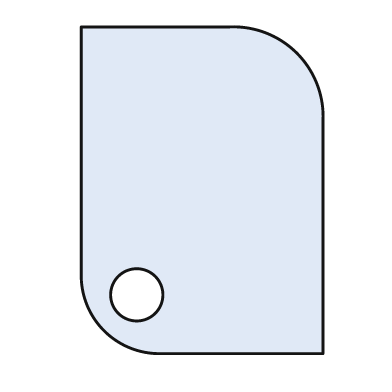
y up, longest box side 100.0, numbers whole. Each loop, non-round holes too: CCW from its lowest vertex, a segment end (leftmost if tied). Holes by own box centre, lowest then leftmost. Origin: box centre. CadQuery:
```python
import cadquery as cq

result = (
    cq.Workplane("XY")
    .moveTo(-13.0, -50.0)
    .lineTo(37.0, -50.0)
    .lineTo(37.0, 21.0)
    .threePointArc((29.0, 42.0), (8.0, 50.0))
    .lineTo(-37.0, 50.0)
    .lineTo(-37.0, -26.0)
    .threePointArc((-30.0, -43.0), (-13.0, -50.0))
    .close()
    .moveTo(-20.0, -32.0)
    .circle(8.0)
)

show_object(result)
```